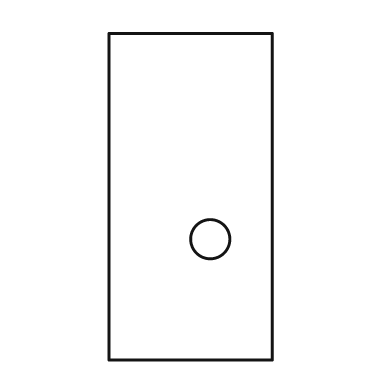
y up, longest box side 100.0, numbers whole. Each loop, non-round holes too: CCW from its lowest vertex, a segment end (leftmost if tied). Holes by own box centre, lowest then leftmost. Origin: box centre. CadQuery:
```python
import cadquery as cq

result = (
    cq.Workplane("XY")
    .moveTo(-25.0, -50.0)
    .lineTo(25.0, -50.0)
    .lineTo(25.0, 50.0)
    .lineTo(-25.0, 50.0)
    .close()
    .moveTo(6.0, -13.0)
    .circle(6.0)
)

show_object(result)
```